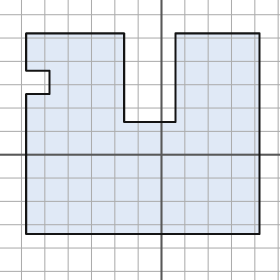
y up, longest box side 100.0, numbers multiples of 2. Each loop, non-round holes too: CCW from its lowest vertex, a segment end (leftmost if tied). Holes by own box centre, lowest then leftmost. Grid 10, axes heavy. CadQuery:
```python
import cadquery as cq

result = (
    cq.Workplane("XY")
    .moveTo(-58.0, -34.0)
    .lineTo(42.0, -34.0)
    .lineTo(42.0, 52.0)
    .lineTo(6.0, 52.0)
    .lineTo(6.0, 14.0)
    .lineTo(-16.0, 14.0)
    .lineTo(-16.0, 52.0)
    .lineTo(-58.0, 52.0)
    .lineTo(-58.0, 36.0)
    .lineTo(-48.0, 36.0)
    .lineTo(-48.0, 26.0)
    .lineTo(-58.0, 26.0)
    .close()
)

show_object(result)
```